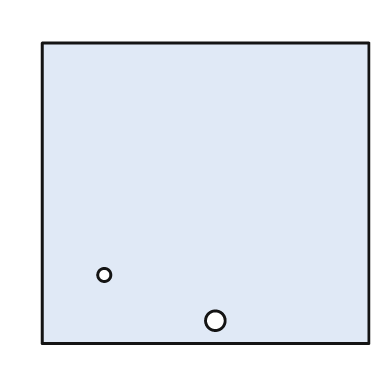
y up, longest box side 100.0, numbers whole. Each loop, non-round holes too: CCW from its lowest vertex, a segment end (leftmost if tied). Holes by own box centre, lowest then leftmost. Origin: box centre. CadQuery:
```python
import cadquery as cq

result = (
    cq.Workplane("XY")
    .moveTo(-50.0, -46.0)
    .lineTo(50.0, -46.0)
    .lineTo(50.0, 46.0)
    .lineTo(-50.0, 46.0)
    .close()
    .moveTo(3.0, -39.0)
    .circle(3.0)
    .moveTo(-31.0, -25.0)
    .circle(2.0)
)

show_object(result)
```